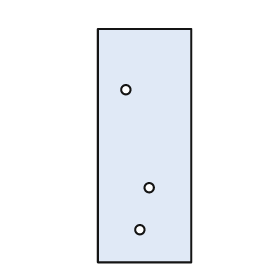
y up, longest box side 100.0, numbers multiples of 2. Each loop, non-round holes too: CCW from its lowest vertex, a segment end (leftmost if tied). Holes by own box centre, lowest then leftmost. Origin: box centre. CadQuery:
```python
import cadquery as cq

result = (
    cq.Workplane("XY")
    .moveTo(-20.0, -50.0)
    .lineTo(20.0, -50.0)
    .lineTo(20.0, 50.0)
    .lineTo(-20.0, 50.0)
    .close()
    .moveTo(-2.0, -36.0)
    .circle(2.0)
    .moveTo(2.0, -18.0)
    .circle(2.0)
    .moveTo(-8.0, 24.0)
    .circle(2.0)
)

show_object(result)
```